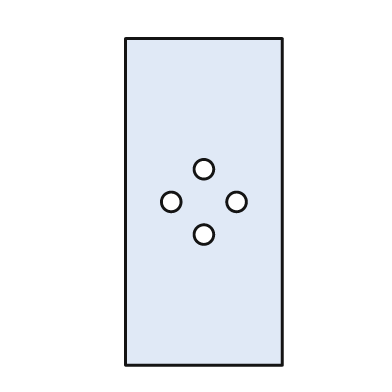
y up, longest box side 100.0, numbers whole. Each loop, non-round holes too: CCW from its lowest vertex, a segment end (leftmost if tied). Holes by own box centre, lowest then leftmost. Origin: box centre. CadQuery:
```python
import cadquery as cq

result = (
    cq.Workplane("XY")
    .moveTo(-24.0, -50.0)
    .lineTo(24.0, -50.0)
    .lineTo(24.0, 50.0)
    .lineTo(-24.0, 50.0)
    .close()
    .moveTo(0.0, -10.0)
    .circle(3.0)
    .moveTo(-10.0, 0.0)
    .circle(3.0)
    .moveTo(10.0, 0.0)
    .circle(3.0)
    .moveTo(0.0, 10.0)
    .circle(3.0)
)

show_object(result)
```